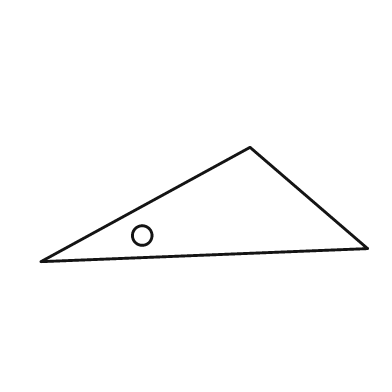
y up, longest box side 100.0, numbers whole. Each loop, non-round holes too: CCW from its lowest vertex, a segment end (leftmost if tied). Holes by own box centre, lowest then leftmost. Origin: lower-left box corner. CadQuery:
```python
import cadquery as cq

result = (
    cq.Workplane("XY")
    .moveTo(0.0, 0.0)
    .lineTo(100.0, 4.0)
    .lineTo(64.0, 35.0)
    .close()
    .moveTo(31.0, 8.0)
    .circle(3.0)
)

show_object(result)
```